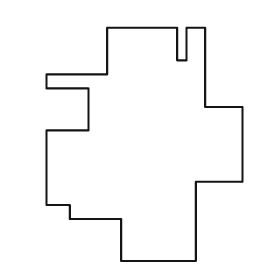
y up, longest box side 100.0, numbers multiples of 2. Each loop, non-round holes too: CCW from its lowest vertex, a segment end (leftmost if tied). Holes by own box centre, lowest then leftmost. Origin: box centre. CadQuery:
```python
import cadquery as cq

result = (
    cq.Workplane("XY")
    .moveTo(-10.0, -50.0)
    .lineTo(22.0, -50.0)
    .lineTo(22.0, -16.0)
    .lineTo(42.0, -16.0)
    .lineTo(42.0, 16.0)
    .lineTo(26.0, 16.0)
    .lineTo(26.0, 50.0)
    .lineTo(18.0, 50.0)
    .lineTo(18.0, 36.0)
    .lineTo(14.0, 36.0)
    .lineTo(14.0, 50.0)
    .lineTo(-16.0, 50.0)
    .lineTo(-16.0, 30.0)
    .lineTo(-42.0, 30.0)
    .lineTo(-42.0, 24.0)
    .lineTo(-24.0, 24.0)
    .lineTo(-24.0, 6.0)
    .lineTo(-42.0, 6.0)
    .lineTo(-42.0, -26.0)
    .lineTo(-32.0, -26.0)
    .lineTo(-32.0, -32.0)
    .lineTo(-10.0, -32.0)
    .close()
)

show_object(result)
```